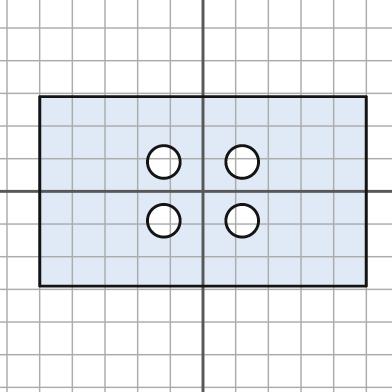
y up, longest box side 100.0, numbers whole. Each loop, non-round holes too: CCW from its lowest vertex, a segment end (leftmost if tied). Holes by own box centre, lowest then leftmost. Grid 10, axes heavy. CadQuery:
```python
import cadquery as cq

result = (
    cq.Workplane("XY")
    .moveTo(-50.0, -29.0)
    .lineTo(50.0, -29.0)
    .lineTo(50.0, 29.0)
    .lineTo(-50.0, 29.0)
    .close()
    .moveTo(-12.0, -9.0)
    .circle(5.0)
    .moveTo(12.0, -9.0)
    .circle(5.0)
    .moveTo(-12.0, 9.0)
    .circle(5.0)
    .moveTo(12.0, 9.0)
    .circle(5.0)
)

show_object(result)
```